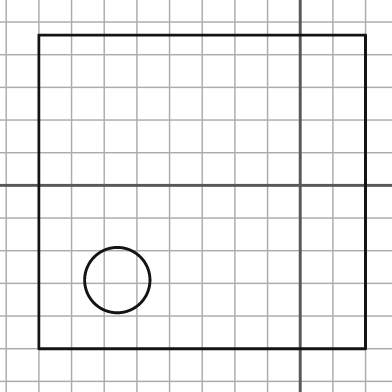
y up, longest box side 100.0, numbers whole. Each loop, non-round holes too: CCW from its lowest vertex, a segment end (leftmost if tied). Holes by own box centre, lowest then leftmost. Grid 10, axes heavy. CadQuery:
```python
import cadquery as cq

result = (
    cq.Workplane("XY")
    .moveTo(-80.0, -50.0)
    .lineTo(20.0, -50.0)
    .lineTo(20.0, 46.0)
    .lineTo(-80.0, 46.0)
    .close()
    .moveTo(-56.0, -29.0)
    .circle(10.0)
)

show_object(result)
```